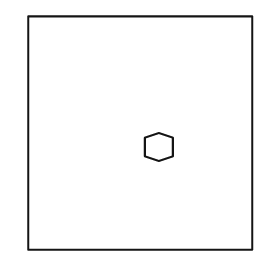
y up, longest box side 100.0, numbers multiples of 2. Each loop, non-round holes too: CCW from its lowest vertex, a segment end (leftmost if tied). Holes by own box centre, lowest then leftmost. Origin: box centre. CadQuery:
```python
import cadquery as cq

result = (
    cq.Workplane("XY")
    .moveTo(-48.0, -50.0)
    .lineTo(48.0, -50.0)
    .lineTo(48.0, 50.0)
    .lineTo(-48.0, 50.0)
    .close()
    .moveTo(8.0, -12.0)
    .lineTo(14.0, -10.0)
    .lineTo(14.0, -2.0)
    .lineTo(8.0, 0.0)
    .lineTo(2.0, -2.0)
    .lineTo(2.0, -10.0)
    .close()
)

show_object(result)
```